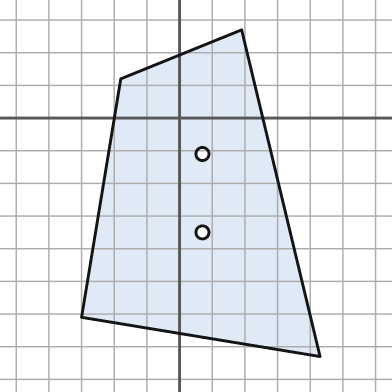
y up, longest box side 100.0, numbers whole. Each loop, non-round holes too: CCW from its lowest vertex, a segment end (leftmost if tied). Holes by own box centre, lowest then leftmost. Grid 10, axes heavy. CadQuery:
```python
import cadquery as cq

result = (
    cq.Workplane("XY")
    .moveTo(43.0, -73.0)
    .lineTo(19.0, 27.0)
    .lineTo(-18.0, 12.0)
    .lineTo(-30.0, -61.0)
    .close()
    .moveTo(7.0, -35.0)
    .circle(2.0)
    .moveTo(7.0, -11.0)
    .circle(2.0)
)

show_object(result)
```